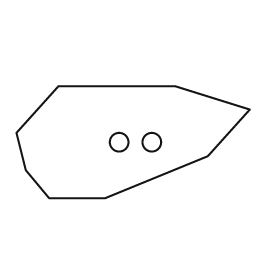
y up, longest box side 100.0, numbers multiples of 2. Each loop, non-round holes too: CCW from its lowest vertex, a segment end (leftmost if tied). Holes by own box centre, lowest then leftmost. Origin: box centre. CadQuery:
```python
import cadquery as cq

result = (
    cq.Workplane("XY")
    .moveTo(-36.0, -24.0)
    .lineTo(-12.0, -24.0)
    .lineTo(32.0, -6.0)
    .lineTo(50.0, 14.0)
    .lineTo(18.0, 24.0)
    .lineTo(-32.0, 24.0)
    .lineTo(-50.0, 4.0)
    .lineTo(-46.0, -12.0)
    .close()
    .moveTo(-6.0, 0.0)
    .circle(4.0)
    .moveTo(8.0, 0.0)
    .circle(4.0)
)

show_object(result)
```